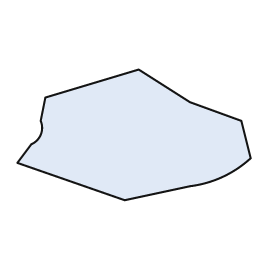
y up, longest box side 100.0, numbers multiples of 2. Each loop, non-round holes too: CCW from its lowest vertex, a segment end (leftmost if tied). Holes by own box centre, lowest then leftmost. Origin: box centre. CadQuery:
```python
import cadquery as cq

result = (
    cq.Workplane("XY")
    .moveTo(-4.0, -28.0)
    .lineTo(24.0, -22.0)
    .threePointArc((38.0, -18.0), (50.0, -10.0))
    .lineTo(46.0, 6.0)
    .lineTo(24.0, 14.0)
    .lineTo(2.0, 28.0)
    .lineTo(-38.0, 16.0)
    .lineTo(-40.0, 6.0)
    .threePointArc((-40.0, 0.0), (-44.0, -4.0))
    .lineTo(-50.0, -12.0)
    .close()
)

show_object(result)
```